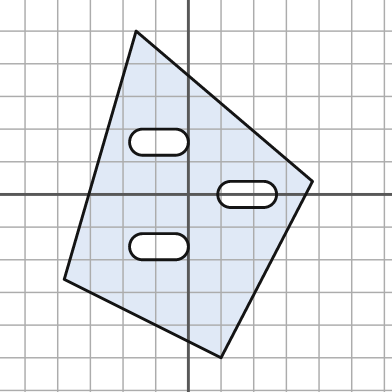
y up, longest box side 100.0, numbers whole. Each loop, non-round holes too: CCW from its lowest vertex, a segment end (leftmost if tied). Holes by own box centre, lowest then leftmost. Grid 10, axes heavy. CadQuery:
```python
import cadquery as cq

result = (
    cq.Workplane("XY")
    .moveTo(10.0, -50.0)
    .lineTo(38.0, 4.0)
    .lineTo(-16.0, 50.0)
    .lineTo(-38.0, -26.0)
    .close()
    .moveTo(-14.0, -20.0)
    .lineTo(-4.0, -20.0)
    .threePointArc((0.0, -16.0), (-4.0, -12.0))
    .lineTo(-14.0, -12.0)
    .threePointArc((-18.0, -16.0), (-14.0, -20.0))
    .close()
    .moveTo(13.0, -4.0)
    .lineTo(23.0, -4.0)
    .threePointArc((27.0, 0.0), (23.0, 4.0))
    .lineTo(13.0, 4.0)
    .threePointArc((9.0, 0.0), (13.0, -4.0))
    .close()
    .moveTo(-14.0, 12.0)
    .lineTo(-4.0, 12.0)
    .threePointArc((0.0, 16.0), (-4.0, 20.0))
    .lineTo(-14.0, 20.0)
    .threePointArc((-18.0, 16.0), (-14.0, 12.0))
    .close()
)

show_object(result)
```